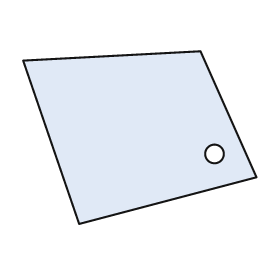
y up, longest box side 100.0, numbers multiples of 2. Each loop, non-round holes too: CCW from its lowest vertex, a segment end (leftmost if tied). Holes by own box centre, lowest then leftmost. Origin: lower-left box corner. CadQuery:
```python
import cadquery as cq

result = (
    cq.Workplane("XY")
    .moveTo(24.0, 0.0)
    .lineTo(100.0, 20.0)
    .lineTo(76.0, 74.0)
    .lineTo(0.0, 70.0)
    .close()
    .moveTo(82.0, 30.0)
    .circle(4.0)
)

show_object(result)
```